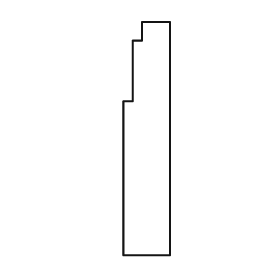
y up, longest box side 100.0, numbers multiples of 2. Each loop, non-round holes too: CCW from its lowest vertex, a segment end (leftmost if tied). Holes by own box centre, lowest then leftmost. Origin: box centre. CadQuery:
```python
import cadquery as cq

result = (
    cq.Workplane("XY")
    .moveTo(-10.0, -50.0)
    .lineTo(10.0, -50.0)
    .lineTo(10.0, 50.0)
    .lineTo(-2.0, 50.0)
    .lineTo(-2.0, 42.0)
    .lineTo(-6.0, 42.0)
    .lineTo(-6.0, 16.0)
    .lineTo(-10.0, 16.0)
    .close()
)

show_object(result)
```